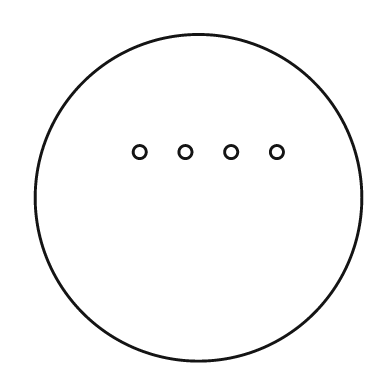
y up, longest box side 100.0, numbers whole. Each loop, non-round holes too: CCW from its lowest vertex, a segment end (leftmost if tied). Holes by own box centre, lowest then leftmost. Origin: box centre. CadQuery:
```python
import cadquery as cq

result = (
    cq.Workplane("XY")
    .moveTo(0.0, 0.0)
    .circle(50.0)
    .moveTo(-18.0, 14.0)
    .circle(2.0)
    .moveTo(-4.0, 14.0)
    .circle(2.0)
    .moveTo(10.0, 14.0)
    .circle(2.0)
    .moveTo(24.0, 14.0)
    .circle(2.0)
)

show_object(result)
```